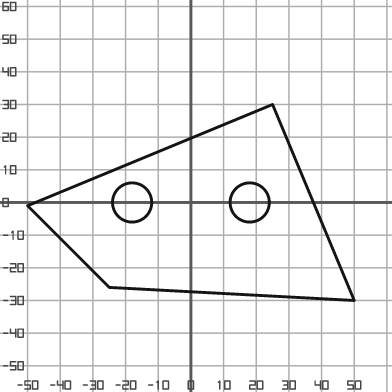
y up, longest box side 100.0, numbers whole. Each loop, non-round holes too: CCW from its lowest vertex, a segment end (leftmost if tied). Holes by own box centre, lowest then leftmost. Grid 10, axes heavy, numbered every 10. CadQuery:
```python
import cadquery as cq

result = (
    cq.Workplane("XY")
    .moveTo(50.0, -30.0)
    .lineTo(25.0, 30.0)
    .lineTo(-50.0, -1.0)
    .lineTo(-25.0, -26.0)
    .close()
    .moveTo(-18.0, 0.0)
    .circle(6.0)
    .moveTo(18.0, 0.0)
    .circle(6.0)
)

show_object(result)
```